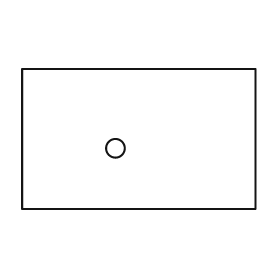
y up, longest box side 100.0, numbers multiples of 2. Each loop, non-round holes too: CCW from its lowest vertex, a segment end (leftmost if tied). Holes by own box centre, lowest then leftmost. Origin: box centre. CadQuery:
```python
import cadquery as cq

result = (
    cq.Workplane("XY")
    .moveTo(-50.0, -30.0)
    .lineTo(50.0, -30.0)
    .lineTo(50.0, 30.0)
    .lineTo(-50.0, 30.0)
    .close()
    .moveTo(-10.0, -4.0)
    .circle(4.0)
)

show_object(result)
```